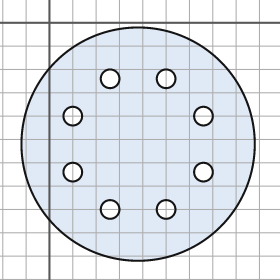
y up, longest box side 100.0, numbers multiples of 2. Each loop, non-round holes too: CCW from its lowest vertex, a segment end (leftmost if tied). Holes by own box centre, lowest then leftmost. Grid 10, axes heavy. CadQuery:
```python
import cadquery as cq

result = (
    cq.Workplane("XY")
    .moveTo(38.0, -52.0)
    .circle(50.0)
    .moveTo(26.0, -80.0)
    .circle(4.0)
    .moveTo(50.0, -80.0)
    .circle(4.0)
    .moveTo(10.0, -64.0)
    .circle(4.0)
    .moveTo(66.0, -64.0)
    .circle(4.0)
    .moveTo(10.0, -40.0)
    .circle(4.0)
    .moveTo(66.0, -40.0)
    .circle(4.0)
    .moveTo(26.0, -24.0)
    .circle(4.0)
    .moveTo(50.0, -24.0)
    .circle(4.0)
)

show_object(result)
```